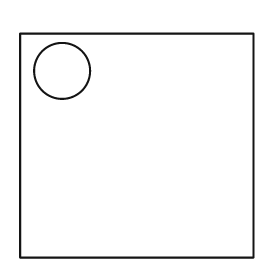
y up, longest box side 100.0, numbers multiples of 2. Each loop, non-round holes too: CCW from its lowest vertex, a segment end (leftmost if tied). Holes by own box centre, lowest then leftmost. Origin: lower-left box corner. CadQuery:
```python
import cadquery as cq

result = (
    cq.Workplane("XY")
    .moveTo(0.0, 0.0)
    .lineTo(100.0, 0.0)
    .lineTo(100.0, 96.0)
    .lineTo(0.0, 96.0)
    .close()
    .moveTo(18.0, 80.0)
    .circle(12.0)
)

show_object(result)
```